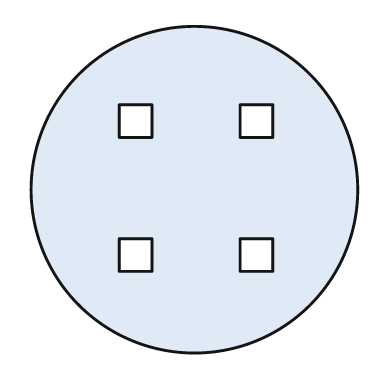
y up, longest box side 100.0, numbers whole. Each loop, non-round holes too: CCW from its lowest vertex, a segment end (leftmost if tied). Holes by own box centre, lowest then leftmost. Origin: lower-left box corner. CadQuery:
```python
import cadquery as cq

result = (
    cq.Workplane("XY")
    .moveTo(50.0, 50.0)
    .circle(50.0)
    .moveTo(27.0, 25.0)
    .lineTo(37.0, 25.0)
    .lineTo(37.0, 35.0)
    .lineTo(27.0, 35.0)
    .close()
    .moveTo(64.0, 25.0)
    .lineTo(74.0, 25.0)
    .lineTo(74.0, 35.0)
    .lineTo(64.0, 35.0)
    .close()
    .moveTo(27.0, 66.0)
    .lineTo(37.0, 66.0)
    .lineTo(37.0, 76.0)
    .lineTo(27.0, 76.0)
    .close()
    .moveTo(64.0, 66.0)
    .lineTo(74.0, 66.0)
    .lineTo(74.0, 76.0)
    .lineTo(64.0, 76.0)
    .close()
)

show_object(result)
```